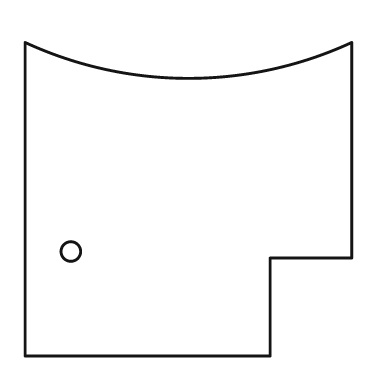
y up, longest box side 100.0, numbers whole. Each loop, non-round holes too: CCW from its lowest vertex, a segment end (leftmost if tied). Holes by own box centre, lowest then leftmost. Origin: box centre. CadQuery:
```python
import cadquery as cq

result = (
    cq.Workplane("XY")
    .moveTo(-50.0, -48.0)
    .lineTo(25.0, -48.0)
    .lineTo(25.0, -18.0)
    .lineTo(50.0, -18.0)
    .lineTo(50.0, 48.0)
    .threePointArc((0.0, 37.0), (-50.0, 48.0))
    .close()
    .moveTo(-36.0, -16.0)
    .circle(3.0)
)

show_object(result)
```